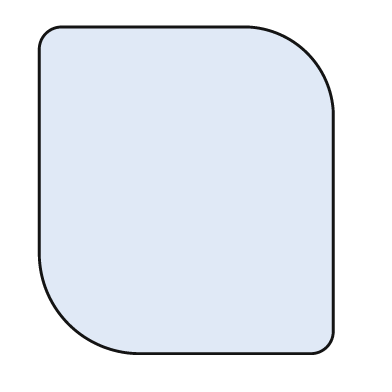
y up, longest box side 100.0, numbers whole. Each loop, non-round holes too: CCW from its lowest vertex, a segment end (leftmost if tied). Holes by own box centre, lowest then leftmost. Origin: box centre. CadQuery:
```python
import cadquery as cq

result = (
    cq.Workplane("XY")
    .moveTo(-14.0, -50.0)
    .lineTo(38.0, -50.0)
    .threePointArc((43.0, -48.0), (45.0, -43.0))
    .lineTo(45.0, 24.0)
    .threePointArc((37.0, 42.0), (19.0, 50.0))
    .lineTo(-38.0, 50.0)
    .threePointArc((-43.0, 48.0), (-45.0, 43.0))
    .lineTo(-45.0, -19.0)
    .threePointArc((-36.0, -41.0), (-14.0, -50.0))
    .close()
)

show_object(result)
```